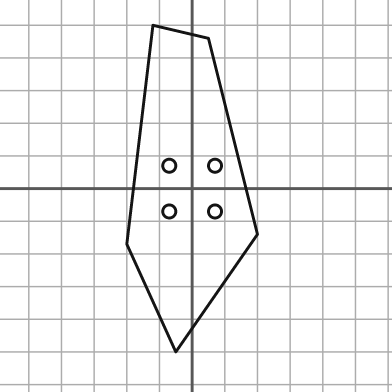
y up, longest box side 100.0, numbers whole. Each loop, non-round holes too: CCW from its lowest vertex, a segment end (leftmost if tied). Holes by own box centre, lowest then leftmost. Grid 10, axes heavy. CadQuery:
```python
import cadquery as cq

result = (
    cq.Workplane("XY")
    .moveTo(-5.0, -50.0)
    .lineTo(20.0, -14.0)
    .lineTo(5.0, 46.0)
    .lineTo(-12.0, 50.0)
    .lineTo(-20.0, -17.0)
    .close()
    .moveTo(-7.0, -7.0)
    .circle(2.0)
    .moveTo(7.0, -7.0)
    .circle(2.0)
    .moveTo(-7.0, 7.0)
    .circle(2.0)
    .moveTo(7.0, 7.0)
    .circle(2.0)
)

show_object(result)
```